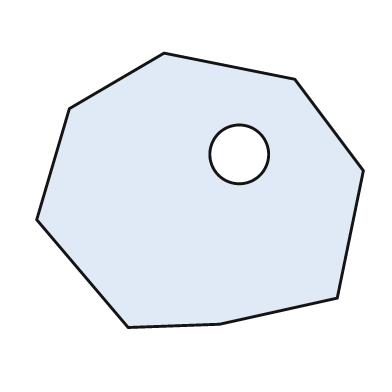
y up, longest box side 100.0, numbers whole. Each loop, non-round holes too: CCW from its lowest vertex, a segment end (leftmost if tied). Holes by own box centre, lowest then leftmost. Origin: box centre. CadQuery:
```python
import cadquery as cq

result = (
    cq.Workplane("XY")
    .moveTo(-22.0, -42.0)
    .lineTo(6.0, -41.0)
    .lineTo(42.0, -33.0)
    .lineTo(50.0, 6.0)
    .lineTo(29.0, 34.0)
    .lineTo(-11.0, 42.0)
    .lineTo(-40.0, 25.0)
    .lineTo(-50.0, -9.0)
    .close()
    .moveTo(12.0, 11.0)
    .circle(9.0)
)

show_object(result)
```